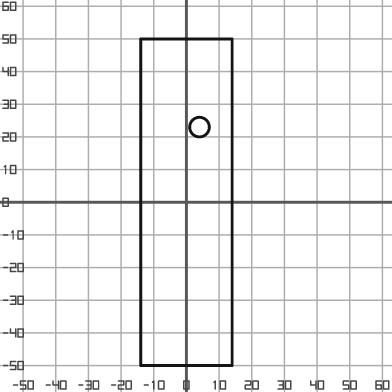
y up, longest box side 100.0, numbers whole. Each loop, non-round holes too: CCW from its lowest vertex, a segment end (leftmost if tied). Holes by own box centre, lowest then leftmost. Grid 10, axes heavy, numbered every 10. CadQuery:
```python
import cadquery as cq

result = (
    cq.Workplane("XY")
    .moveTo(-14.0, -50.0)
    .lineTo(14.0, -50.0)
    .lineTo(14.0, 50.0)
    .lineTo(-14.0, 50.0)
    .close()
    .moveTo(4.0, 23.0)
    .circle(3.0)
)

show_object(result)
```